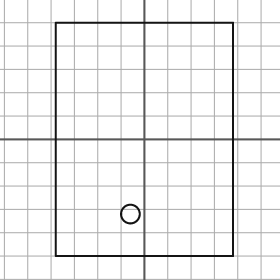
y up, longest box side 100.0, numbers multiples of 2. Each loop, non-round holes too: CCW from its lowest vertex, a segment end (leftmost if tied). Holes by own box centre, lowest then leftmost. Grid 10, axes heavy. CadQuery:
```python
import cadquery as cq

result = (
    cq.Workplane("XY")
    .moveTo(-38.0, -50.0)
    .lineTo(38.0, -50.0)
    .lineTo(38.0, 50.0)
    .lineTo(-38.0, 50.0)
    .close()
    .moveTo(-6.0, -32.0)
    .circle(4.0)
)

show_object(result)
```